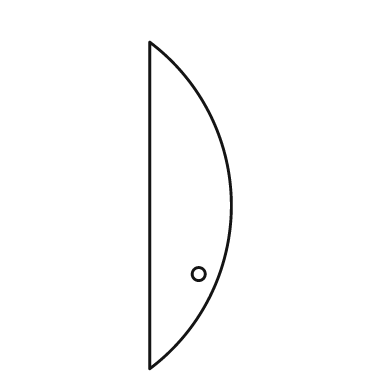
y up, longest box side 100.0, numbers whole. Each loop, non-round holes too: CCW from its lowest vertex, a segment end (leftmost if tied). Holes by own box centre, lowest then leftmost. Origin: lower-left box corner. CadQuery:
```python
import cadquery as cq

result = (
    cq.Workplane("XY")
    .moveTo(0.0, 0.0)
    .threePointArc((25.0, 50.0), (0.0, 100.0))
    .close()
    .moveTo(15.0, 29.0)
    .circle(2.0)
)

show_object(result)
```